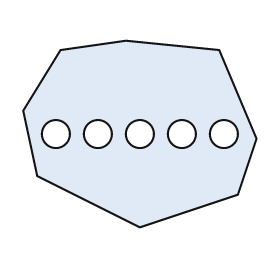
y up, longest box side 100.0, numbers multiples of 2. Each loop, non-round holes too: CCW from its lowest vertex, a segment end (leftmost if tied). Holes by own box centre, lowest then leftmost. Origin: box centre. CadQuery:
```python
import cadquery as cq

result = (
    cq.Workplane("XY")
    .moveTo(0.0, -40.0)
    .lineTo(42.0, -26.0)
    .lineTo(50.0, -2.0)
    .lineTo(34.0, 36.0)
    .lineTo(-6.0, 40.0)
    .lineTo(-34.0, 36.0)
    .lineTo(-50.0, 10.0)
    .lineTo(-44.0, -18.0)
    .close()
    .moveTo(-36.0, 0.0)
    .circle(6.0)
    .moveTo(-18.0, 0.0)
    .circle(6.0)
    .moveTo(0.0, 0.0)
    .circle(6.0)
    .moveTo(18.0, 0.0)
    .circle(6.0)
    .moveTo(36.0, 0.0)
    .circle(6.0)
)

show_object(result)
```